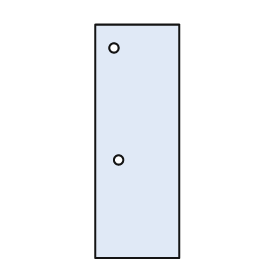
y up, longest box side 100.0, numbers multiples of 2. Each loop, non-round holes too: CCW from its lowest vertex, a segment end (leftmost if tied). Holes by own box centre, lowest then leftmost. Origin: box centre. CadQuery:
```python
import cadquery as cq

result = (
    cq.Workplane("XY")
    .moveTo(-18.0, -50.0)
    .lineTo(18.0, -50.0)
    .lineTo(18.0, 50.0)
    .lineTo(-18.0, 50.0)
    .close()
    .moveTo(-8.0, -8.0)
    .circle(2.0)
    .moveTo(-10.0, 40.0)
    .circle(2.0)
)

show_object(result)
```